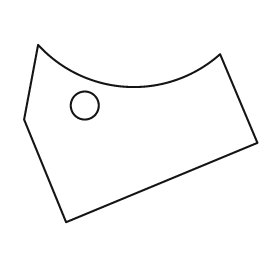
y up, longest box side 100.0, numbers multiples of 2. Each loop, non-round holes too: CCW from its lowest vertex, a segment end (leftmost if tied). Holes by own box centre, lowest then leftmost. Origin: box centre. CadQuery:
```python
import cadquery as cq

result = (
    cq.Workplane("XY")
    .moveTo(-32.0, -38.0)
    .lineTo(50.0, -4.0)
    .lineTo(34.0, 34.0)
    .threePointArc((-6.0, 20.0), (-44.0, 38.0))
    .lineTo(-50.0, 6.0)
    .close()
    .moveTo(-24.0, 12.0)
    .circle(6.0)
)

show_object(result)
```